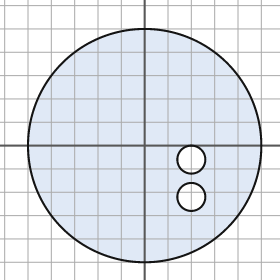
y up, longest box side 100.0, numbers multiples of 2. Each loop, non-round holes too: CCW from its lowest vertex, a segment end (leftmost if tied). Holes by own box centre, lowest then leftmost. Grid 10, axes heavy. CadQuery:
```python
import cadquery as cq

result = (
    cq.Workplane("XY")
    .moveTo(0.0, 0.0)
    .circle(50.0)
    .moveTo(20.0, -22.0)
    .circle(6.0)
    .moveTo(20.0, -6.0)
    .circle(6.0)
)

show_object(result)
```